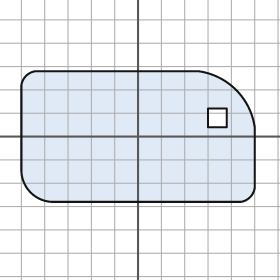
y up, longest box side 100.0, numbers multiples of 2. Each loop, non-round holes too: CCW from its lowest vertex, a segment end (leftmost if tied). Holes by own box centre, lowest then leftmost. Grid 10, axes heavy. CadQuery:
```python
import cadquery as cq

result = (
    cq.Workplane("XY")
    .moveTo(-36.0, -28.0)
    .lineTo(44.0, -28.0)
    .threePointArc((48.0, -26.0), (50.0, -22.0))
    .lineTo(50.0, 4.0)
    .threePointArc((42.0, 20.0), (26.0, 28.0))
    .lineTo(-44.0, 28.0)
    .threePointArc((-48.0, 26.0), (-50.0, 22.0))
    .lineTo(-50.0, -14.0)
    .threePointArc((-46.0, -24.0), (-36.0, -28.0))
    .close()
    .moveTo(30.0, 4.0)
    .lineTo(38.0, 4.0)
    .lineTo(38.0, 12.0)
    .lineTo(30.0, 12.0)
    .close()
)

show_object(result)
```